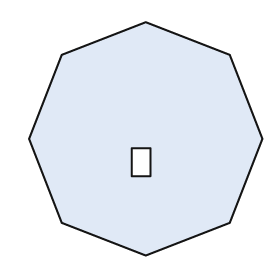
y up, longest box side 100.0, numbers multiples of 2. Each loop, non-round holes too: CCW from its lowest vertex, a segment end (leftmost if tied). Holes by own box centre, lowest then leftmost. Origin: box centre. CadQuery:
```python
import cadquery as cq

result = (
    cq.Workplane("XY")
    .moveTo(0.0, -50.0)
    .lineTo(36.0, -36.0)
    .lineTo(50.0, 0.0)
    .lineTo(36.0, 36.0)
    .lineTo(0.0, 50.0)
    .lineTo(-36.0, 36.0)
    .lineTo(-50.0, 0.0)
    .lineTo(-36.0, -36.0)
    .close()
    .moveTo(-6.0, -16.0)
    .lineTo(2.0, -16.0)
    .lineTo(2.0, -4.0)
    .lineTo(-6.0, -4.0)
    .close()
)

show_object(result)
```